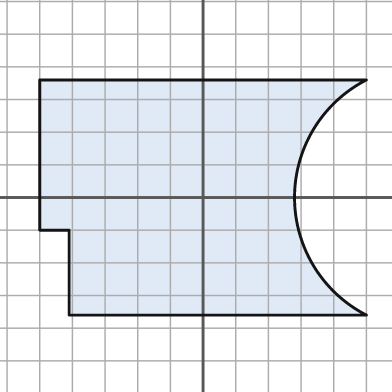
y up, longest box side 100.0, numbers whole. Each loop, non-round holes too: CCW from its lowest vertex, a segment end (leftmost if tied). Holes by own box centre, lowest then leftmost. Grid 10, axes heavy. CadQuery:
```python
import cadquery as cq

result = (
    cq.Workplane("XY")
    .moveTo(-41.0, -36.0)
    .lineTo(50.0, -36.0)
    .threePointArc((28.0, 0.0), (50.0, 36.0))
    .lineTo(-50.0, 36.0)
    .lineTo(-50.0, -10.0)
    .lineTo(-41.0, -10.0)
    .close()
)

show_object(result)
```